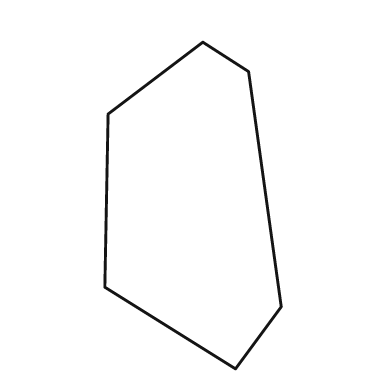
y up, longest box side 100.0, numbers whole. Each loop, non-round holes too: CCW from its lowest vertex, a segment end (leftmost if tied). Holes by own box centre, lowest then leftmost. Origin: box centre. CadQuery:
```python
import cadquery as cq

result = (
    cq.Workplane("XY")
    .moveTo(13.0, -50.0)
    .lineTo(27.0, -31.0)
    .lineTo(17.0, 41.0)
    .lineTo(3.0, 50.0)
    .lineTo(-26.0, 28.0)
    .lineTo(-27.0, -25.0)
    .close()
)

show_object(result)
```